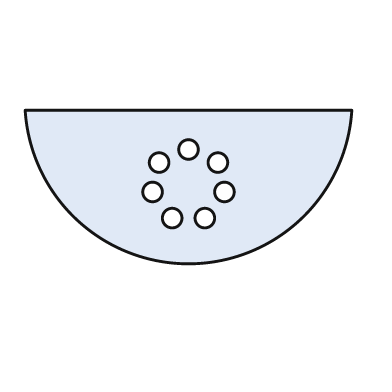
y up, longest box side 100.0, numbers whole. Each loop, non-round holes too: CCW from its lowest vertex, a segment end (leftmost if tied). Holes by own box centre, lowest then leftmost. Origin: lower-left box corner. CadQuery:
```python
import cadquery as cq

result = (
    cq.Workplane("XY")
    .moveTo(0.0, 47.0)
    .threePointArc((50.0, 0.0), (100.0, 47.0))
    .close()
    .moveTo(45.0, 14.0)
    .circle(3.0)
    .moveTo(55.0, 14.0)
    .circle(3.0)
    .moveTo(39.0, 22.0)
    .circle(3.0)
    .moveTo(61.0, 22.0)
    .circle(3.0)
    .moveTo(41.0, 31.0)
    .circle(3.0)
    .moveTo(59.0, 31.0)
    .circle(3.0)
    .moveTo(50.0, 35.0)
    .circle(3.0)
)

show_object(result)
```